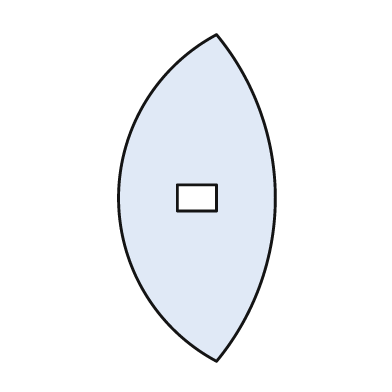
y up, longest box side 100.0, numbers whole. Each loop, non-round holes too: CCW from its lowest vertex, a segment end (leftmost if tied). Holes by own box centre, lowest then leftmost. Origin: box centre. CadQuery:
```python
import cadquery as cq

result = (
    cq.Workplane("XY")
    .moveTo(6.0, -50.0)
    .threePointArc((24.0, 0.0), (6.0, 50.0))
    .threePointArc((-24.0, 0.0), (6.0, -50.0))
    .close()
    .moveTo(-6.0, -4.0)
    .lineTo(6.0, -4.0)
    .lineTo(6.0, 4.0)
    .lineTo(-6.0, 4.0)
    .close()
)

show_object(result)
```